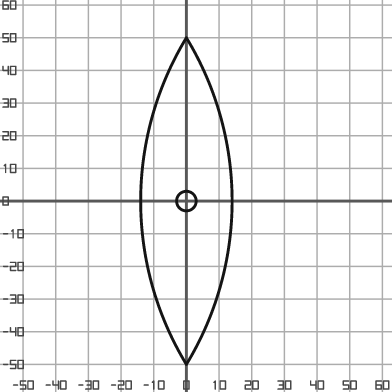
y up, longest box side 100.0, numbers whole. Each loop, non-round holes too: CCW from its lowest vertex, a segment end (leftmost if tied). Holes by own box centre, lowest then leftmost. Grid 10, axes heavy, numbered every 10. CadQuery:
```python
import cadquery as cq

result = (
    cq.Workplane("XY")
    .moveTo(0.0, -50.0)
    .threePointArc((14.0, 0.0), (0.0, 50.0))
    .threePointArc((-14.0, 0.0), (0.0, -50.0))
    .close()
    .moveTo(0.0, 0.0)
    .circle(3.0)
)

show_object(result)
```